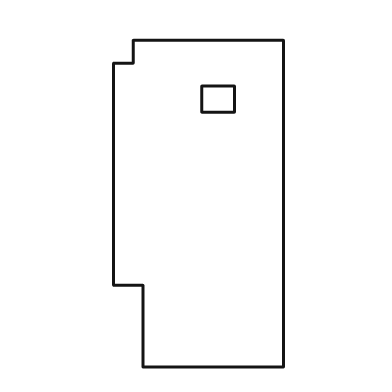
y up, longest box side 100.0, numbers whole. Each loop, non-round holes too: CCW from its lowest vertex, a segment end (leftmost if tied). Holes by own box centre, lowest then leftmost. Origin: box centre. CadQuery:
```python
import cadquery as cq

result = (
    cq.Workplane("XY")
    .moveTo(-17.0, -50.0)
    .lineTo(26.0, -50.0)
    .lineTo(26.0, 50.0)
    .lineTo(-20.0, 50.0)
    .lineTo(-20.0, 43.0)
    .lineTo(-26.0, 43.0)
    .lineTo(-26.0, -25.0)
    .lineTo(-17.0, -25.0)
    .close()
    .moveTo(1.0, 28.0)
    .lineTo(11.0, 28.0)
    .lineTo(11.0, 36.0)
    .lineTo(1.0, 36.0)
    .close()
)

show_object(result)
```